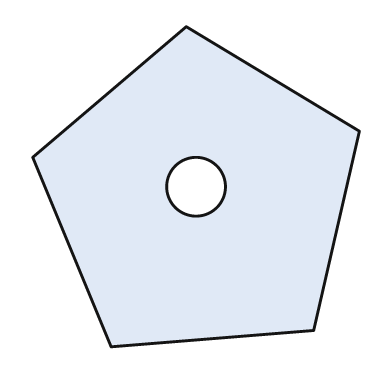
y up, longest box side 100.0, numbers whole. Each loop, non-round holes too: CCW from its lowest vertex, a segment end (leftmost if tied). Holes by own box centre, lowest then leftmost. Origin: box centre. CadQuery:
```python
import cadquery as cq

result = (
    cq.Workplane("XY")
    .moveTo(-26.0, -49.0)
    .lineTo(36.0, -44.0)
    .lineTo(50.0, 17.0)
    .lineTo(-3.0, 49.0)
    .lineTo(-50.0, 9.0)
    .close()
    .moveTo(0.0, 0.0)
    .circle(9.0)
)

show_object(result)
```